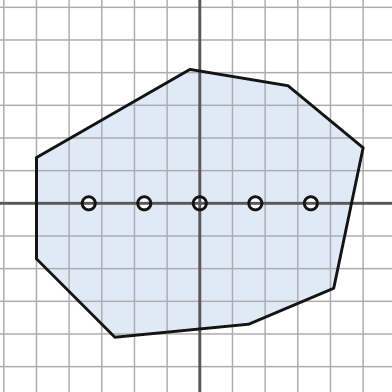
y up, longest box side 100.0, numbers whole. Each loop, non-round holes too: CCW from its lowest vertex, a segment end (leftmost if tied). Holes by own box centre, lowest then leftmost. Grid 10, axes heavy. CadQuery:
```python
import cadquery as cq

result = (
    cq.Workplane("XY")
    .moveTo(-26.0, -41.0)
    .lineTo(15.0, -37.0)
    .lineTo(41.0, -26.0)
    .lineTo(50.0, 17.0)
    .lineTo(27.0, 36.0)
    .lineTo(-3.0, 41.0)
    .lineTo(-50.0, 14.0)
    .lineTo(-50.0, -17.0)
    .close()
    .moveTo(-34.0, 0.0)
    .circle(2.0)
    .moveTo(-17.0, 0.0)
    .circle(2.0)
    .moveTo(0.0, 0.0)
    .circle(2.0)
    .moveTo(17.0, 0.0)
    .circle(2.0)
    .moveTo(34.0, 0.0)
    .circle(2.0)
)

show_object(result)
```